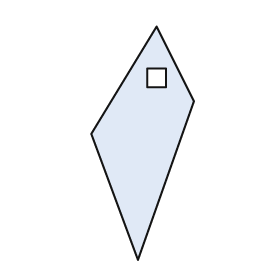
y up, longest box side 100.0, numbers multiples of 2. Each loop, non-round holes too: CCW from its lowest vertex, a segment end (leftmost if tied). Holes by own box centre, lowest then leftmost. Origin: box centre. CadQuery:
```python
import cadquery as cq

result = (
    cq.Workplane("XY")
    .moveTo(-2.0, -50.0)
    .lineTo(22.0, 18.0)
    .lineTo(6.0, 50.0)
    .lineTo(-22.0, 4.0)
    .close()
    .moveTo(2.0, 24.0)
    .lineTo(10.0, 24.0)
    .lineTo(10.0, 32.0)
    .lineTo(2.0, 32.0)
    .close()
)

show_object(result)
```